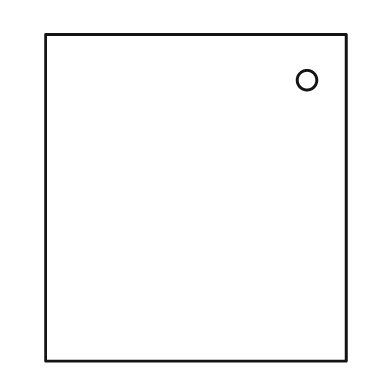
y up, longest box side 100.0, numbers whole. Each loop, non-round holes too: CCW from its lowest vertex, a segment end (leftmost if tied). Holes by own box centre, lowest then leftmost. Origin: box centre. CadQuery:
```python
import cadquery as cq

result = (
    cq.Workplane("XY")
    .moveTo(-46.0, -50.0)
    .lineTo(46.0, -50.0)
    .lineTo(46.0, 50.0)
    .lineTo(-46.0, 50.0)
    .close()
    .moveTo(34.0, 36.0)
    .circle(3.0)
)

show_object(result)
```